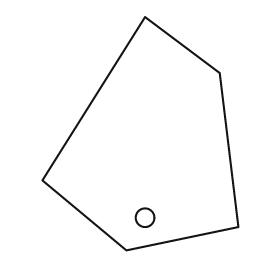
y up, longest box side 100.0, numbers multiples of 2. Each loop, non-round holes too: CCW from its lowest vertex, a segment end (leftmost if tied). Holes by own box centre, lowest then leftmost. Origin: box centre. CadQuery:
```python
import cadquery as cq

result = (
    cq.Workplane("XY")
    .moveTo(-6.0, -50.0)
    .lineTo(42.0, -40.0)
    .lineTo(34.0, 26.0)
    .lineTo(2.0, 50.0)
    .lineTo(-42.0, -20.0)
    .close()
    .moveTo(2.0, -36.0)
    .circle(4.0)
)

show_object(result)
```